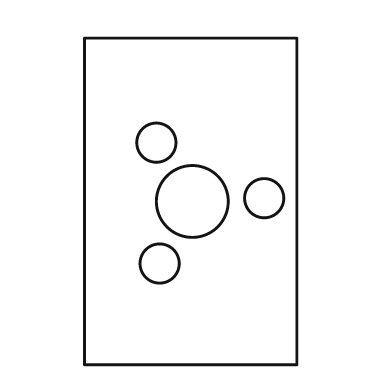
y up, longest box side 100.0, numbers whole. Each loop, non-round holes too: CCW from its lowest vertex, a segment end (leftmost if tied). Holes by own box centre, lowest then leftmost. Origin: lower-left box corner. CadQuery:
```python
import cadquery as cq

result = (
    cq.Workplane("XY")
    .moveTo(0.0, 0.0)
    .lineTo(65.0, 0.0)
    .lineTo(65.0, 100.0)
    .lineTo(0.0, 100.0)
    .close()
    .moveTo(23.0, 31.0)
    .circle(6.0)
    .moveTo(33.0, 50.0)
    .circle(11.0)
    .moveTo(55.0, 51.0)
    .circle(6.0)
    .moveTo(22.0, 68.0)
    .circle(6.0)
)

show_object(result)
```